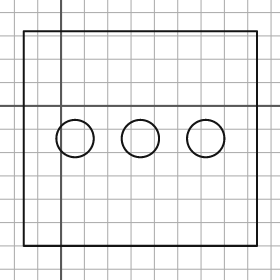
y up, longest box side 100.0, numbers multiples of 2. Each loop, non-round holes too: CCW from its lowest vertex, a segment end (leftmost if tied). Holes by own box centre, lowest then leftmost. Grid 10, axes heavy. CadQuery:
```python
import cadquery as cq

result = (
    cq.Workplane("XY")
    .moveTo(-16.0, -60.0)
    .lineTo(84.0, -60.0)
    .lineTo(84.0, 32.0)
    .lineTo(-16.0, 32.0)
    .close()
    .moveTo(6.0, -14.0)
    .circle(8.0)
    .moveTo(34.0, -14.0)
    .circle(8.0)
    .moveTo(62.0, -14.0)
    .circle(8.0)
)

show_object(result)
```